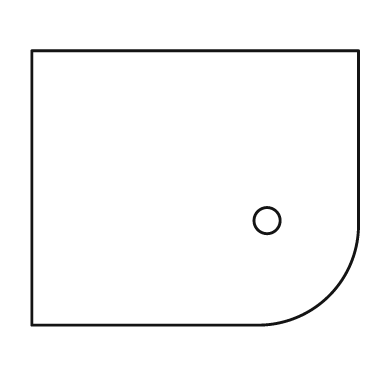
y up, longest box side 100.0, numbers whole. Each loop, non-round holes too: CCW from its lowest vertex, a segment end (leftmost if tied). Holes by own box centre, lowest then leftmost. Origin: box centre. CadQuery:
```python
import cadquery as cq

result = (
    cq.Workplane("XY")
    .moveTo(-50.0, -42.0)
    .lineTo(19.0, -42.0)
    .threePointArc((41.0, -33.0), (50.0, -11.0))
    .lineTo(50.0, 42.0)
    .lineTo(-50.0, 42.0)
    .close()
    .moveTo(22.0, -10.0)
    .circle(4.0)
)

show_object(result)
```